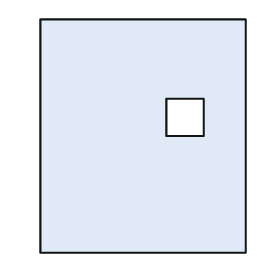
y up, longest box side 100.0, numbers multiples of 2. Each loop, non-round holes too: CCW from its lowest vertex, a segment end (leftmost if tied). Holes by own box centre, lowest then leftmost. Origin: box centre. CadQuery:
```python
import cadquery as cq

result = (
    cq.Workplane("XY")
    .moveTo(-44.0, -50.0)
    .lineTo(44.0, -50.0)
    .lineTo(44.0, 50.0)
    .lineTo(-44.0, 50.0)
    .close()
    .moveTo(10.0, 0.0)
    .lineTo(26.0, 0.0)
    .lineTo(26.0, 16.0)
    .lineTo(10.0, 16.0)
    .close()
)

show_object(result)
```